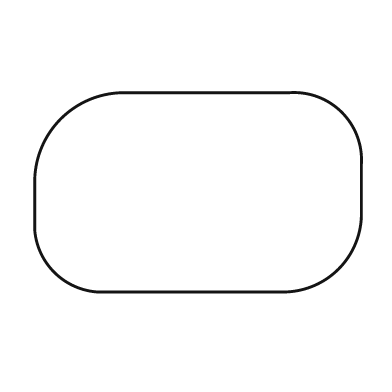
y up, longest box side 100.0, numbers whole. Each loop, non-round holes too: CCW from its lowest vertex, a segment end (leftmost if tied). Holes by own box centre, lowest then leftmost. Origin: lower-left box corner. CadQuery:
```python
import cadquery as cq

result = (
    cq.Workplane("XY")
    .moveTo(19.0, 0.0)
    .lineTo(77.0, 0.0)
    .threePointArc((93.0, 7.0), (100.0, 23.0))
    .lineTo(100.0, 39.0)
    .threePointArc((94.0, 55.0), (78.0, 61.0))
    .lineTo(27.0, 61.0)
    .threePointArc((8.0, 53.0), (0.0, 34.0))
    .lineTo(0.0, 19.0)
    .threePointArc((6.0, 6.0), (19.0, 0.0))
    .close()
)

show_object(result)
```